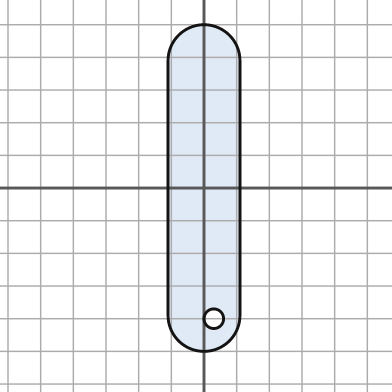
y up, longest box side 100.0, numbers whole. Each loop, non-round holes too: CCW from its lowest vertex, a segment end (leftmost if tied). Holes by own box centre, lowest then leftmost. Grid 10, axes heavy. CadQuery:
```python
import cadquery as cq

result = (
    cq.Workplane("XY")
    .moveTo(-11.0, -39.0)
    .threePointArc((0.0, -50.0), (11.0, -39.0))
    .lineTo(11.0, 39.0)
    .threePointArc((0.0, 50.0), (-11.0, 39.0))
    .close()
    .moveTo(3.0, -40.0)
    .circle(3.0)
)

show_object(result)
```